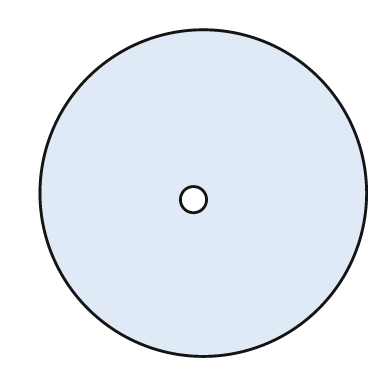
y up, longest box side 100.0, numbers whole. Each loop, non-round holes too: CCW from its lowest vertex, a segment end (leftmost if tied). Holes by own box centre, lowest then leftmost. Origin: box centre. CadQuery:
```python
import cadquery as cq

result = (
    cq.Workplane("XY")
    .moveTo(0.0, 0.0)
    .circle(50.0)
    .moveTo(-3.0, -2.0)
    .circle(4.0)
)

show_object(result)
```